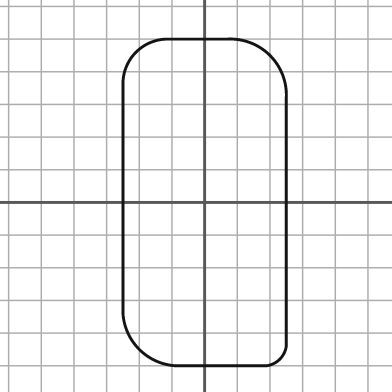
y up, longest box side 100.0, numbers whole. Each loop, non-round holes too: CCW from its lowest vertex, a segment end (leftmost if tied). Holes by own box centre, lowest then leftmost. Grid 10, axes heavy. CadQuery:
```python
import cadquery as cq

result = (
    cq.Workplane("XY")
    .moveTo(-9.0, -50.0)
    .lineTo(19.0, -50.0)
    .threePointArc((23.0, -48.0), (25.0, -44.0))
    .lineTo(25.0, 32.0)
    .threePointArc((20.0, 45.0), (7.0, 50.0))
    .lineTo(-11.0, 50.0)
    .threePointArc((-21.0, 46.0), (-25.0, 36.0))
    .lineTo(-25.0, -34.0)
    .threePointArc((-20.0, -45.0), (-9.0, -50.0))
    .close()
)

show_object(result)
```